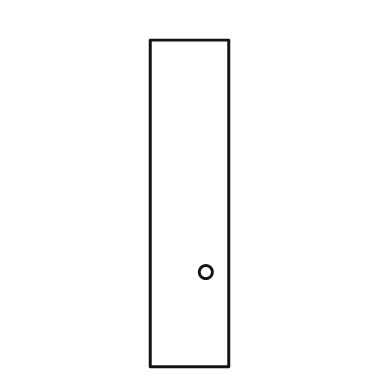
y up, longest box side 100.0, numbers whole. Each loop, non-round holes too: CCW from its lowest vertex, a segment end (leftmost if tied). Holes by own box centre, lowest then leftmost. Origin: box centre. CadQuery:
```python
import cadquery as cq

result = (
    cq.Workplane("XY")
    .moveTo(-12.0, -50.0)
    .lineTo(12.0, -50.0)
    .lineTo(12.0, 50.0)
    .lineTo(-12.0, 50.0)
    .close()
    .moveTo(5.0, -21.0)
    .circle(2.0)
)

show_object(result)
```